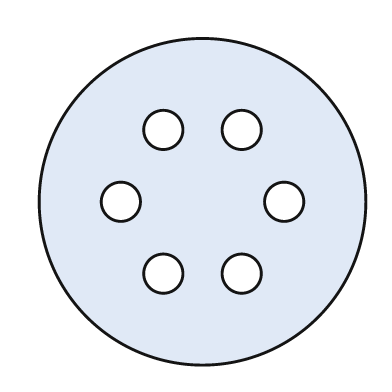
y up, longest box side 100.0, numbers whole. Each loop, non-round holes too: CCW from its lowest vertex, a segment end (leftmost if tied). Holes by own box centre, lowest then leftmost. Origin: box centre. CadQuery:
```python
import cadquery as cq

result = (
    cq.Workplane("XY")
    .moveTo(0.0, 0.0)
    .circle(50.0)
    .moveTo(-12.0, -22.0)
    .circle(6.0)
    .moveTo(12.0, -22.0)
    .circle(6.0)
    .moveTo(-25.0, 0.0)
    .circle(6.0)
    .moveTo(25.0, 0.0)
    .circle(6.0)
    .moveTo(-12.0, 22.0)
    .circle(6.0)
    .moveTo(12.0, 22.0)
    .circle(6.0)
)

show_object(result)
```